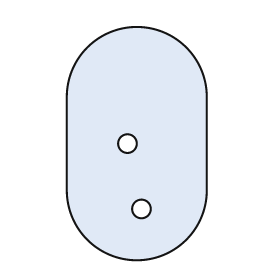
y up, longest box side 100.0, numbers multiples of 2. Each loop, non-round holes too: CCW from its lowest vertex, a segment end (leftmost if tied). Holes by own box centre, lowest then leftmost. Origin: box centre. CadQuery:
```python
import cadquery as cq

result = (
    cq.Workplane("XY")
    .moveTo(-30.0, -20.0)
    .threePointArc((0.0, -50.0), (30.0, -20.0))
    .lineTo(30.0, 20.0)
    .threePointArc((0.0, 50.0), (-30.0, 20.0))
    .close()
    .moveTo(2.0, -28.0)
    .circle(4.0)
    .moveTo(-4.0, 0.0)
    .circle(4.0)
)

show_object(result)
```